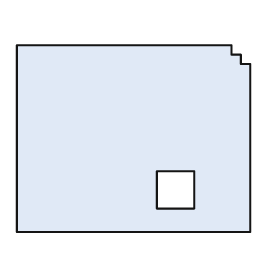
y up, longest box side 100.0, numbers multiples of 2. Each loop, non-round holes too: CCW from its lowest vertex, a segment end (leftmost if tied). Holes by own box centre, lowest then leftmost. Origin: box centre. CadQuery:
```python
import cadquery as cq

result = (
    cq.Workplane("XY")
    .moveTo(-50.0, -40.0)
    .lineTo(50.0, -40.0)
    .lineTo(50.0, 32.0)
    .lineTo(46.0, 32.0)
    .lineTo(46.0, 36.0)
    .lineTo(42.0, 36.0)
    .lineTo(42.0, 40.0)
    .lineTo(-50.0, 40.0)
    .close()
    .moveTo(10.0, -30.0)
    .lineTo(26.0, -30.0)
    .lineTo(26.0, -14.0)
    .lineTo(10.0, -14.0)
    .close()
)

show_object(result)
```